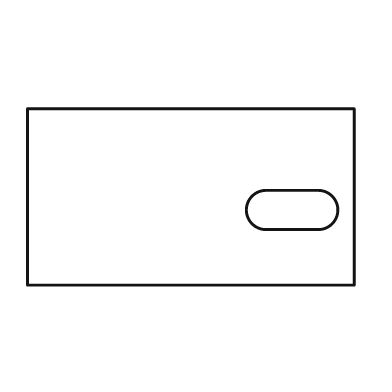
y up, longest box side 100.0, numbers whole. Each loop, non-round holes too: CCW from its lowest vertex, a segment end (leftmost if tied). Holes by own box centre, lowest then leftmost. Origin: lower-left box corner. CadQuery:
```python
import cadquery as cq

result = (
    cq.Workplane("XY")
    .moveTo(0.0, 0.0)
    .lineTo(100.0, 0.0)
    .lineTo(100.0, 54.0)
    .lineTo(0.0, 54.0)
    .close()
    .moveTo(73.0, 17.0)
    .lineTo(89.0, 17.0)
    .threePointArc((95.0, 23.0), (89.0, 29.0))
    .lineTo(73.0, 29.0)
    .threePointArc((67.0, 23.0), (73.0, 17.0))
    .close()
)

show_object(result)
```